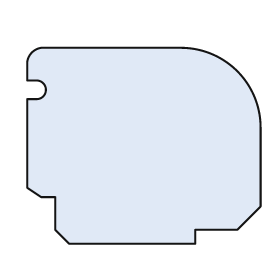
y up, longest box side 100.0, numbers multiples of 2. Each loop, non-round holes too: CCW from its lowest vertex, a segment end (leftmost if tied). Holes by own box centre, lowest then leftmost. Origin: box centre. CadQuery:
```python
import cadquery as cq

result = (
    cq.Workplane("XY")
    .moveTo(-32.0, -42.0)
    .lineTo(22.0, -42.0)
    .lineTo(22.0, -36.0)
    .lineTo(40.0, -36.0)
    .lineTo(50.0, -26.0)
    .lineTo(50.0, 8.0)
    .threePointArc((40.0, 32.0), (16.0, 42.0))
    .lineTo(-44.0, 42.0)
    .threePointArc((-48.0, 40.0), (-50.0, 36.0))
    .lineTo(-50.0, 28.0)
    .lineTo(-46.0, 28.0)
    .threePointArc((-42.0, 24.0), (-46.0, 20.0))
    .lineTo(-50.0, 20.0)
    .lineTo(-50.0, -18.0)
    .lineTo(-44.0, -22.0)
    .lineTo(-38.0, -22.0)
    .lineTo(-38.0, -36.0)
    .close()
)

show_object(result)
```